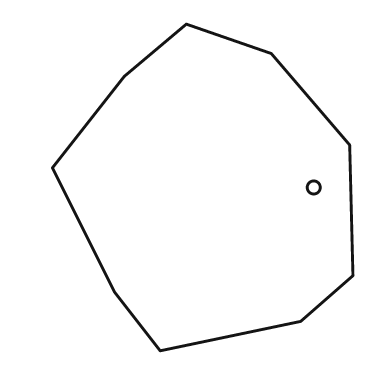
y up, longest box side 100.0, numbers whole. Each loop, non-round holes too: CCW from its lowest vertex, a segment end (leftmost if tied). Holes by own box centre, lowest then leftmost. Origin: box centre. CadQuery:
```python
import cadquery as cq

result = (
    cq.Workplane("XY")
    .moveTo(-13.0, -50.0)
    .lineTo(30.0, -41.0)
    .lineTo(46.0, -27.0)
    .lineTo(45.0, 13.0)
    .lineTo(21.0, 41.0)
    .lineTo(-5.0, 50.0)
    .lineTo(-24.0, 34.0)
    .lineTo(-46.0, 6.0)
    .lineTo(-27.0, -32.0)
    .close()
    .moveTo(34.0, 0.0)
    .circle(2.0)
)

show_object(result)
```